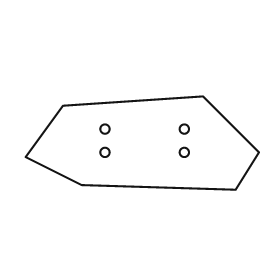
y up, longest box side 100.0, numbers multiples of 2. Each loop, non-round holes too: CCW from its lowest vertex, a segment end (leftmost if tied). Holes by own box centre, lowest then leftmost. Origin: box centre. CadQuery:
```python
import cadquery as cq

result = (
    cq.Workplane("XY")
    .moveTo(40.0, -20.0)
    .lineTo(50.0, -4.0)
    .lineTo(26.0, 20.0)
    .lineTo(-34.0, 16.0)
    .lineTo(-50.0, -6.0)
    .lineTo(-26.0, -18.0)
    .close()
    .moveTo(-16.0, -4.0)
    .circle(2.0)
    .moveTo(18.0, -4.0)
    .circle(2.0)
    .moveTo(-16.0, 6.0)
    .circle(2.0)
    .moveTo(18.0, 6.0)
    .circle(2.0)
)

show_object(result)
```